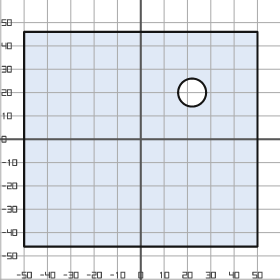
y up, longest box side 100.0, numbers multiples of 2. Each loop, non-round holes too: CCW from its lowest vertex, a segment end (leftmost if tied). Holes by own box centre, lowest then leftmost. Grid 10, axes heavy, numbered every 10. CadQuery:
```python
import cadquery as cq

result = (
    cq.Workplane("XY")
    .moveTo(-50.0, -46.0)
    .lineTo(50.0, -46.0)
    .lineTo(50.0, 46.0)
    .lineTo(-50.0, 46.0)
    .close()
    .moveTo(22.0, 20.0)
    .circle(6.0)
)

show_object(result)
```